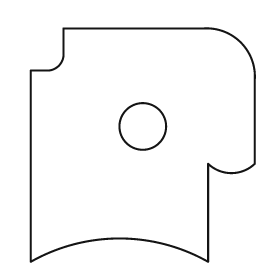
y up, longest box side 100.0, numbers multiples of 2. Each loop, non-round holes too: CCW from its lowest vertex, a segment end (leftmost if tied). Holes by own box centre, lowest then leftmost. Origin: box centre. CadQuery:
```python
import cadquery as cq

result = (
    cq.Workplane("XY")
    .moveTo(-48.0, -50.0)
    .threePointArc((-10.0, -40.0), (28.0, -50.0))
    .lineTo(28.0, -8.0)
    .threePointArc((38.0, -12.0), (48.0, -8.0))
    .lineTo(48.0, 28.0)
    .threePointArc((42.0, 44.0), (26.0, 50.0))
    .lineTo(-34.0, 50.0)
    .lineTo(-34.0, 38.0)
    .threePointArc((-36.0, 34.0), (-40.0, 32.0))
    .lineTo(-48.0, 32.0)
    .close()
    .moveTo(0.0, 8.0)
    .circle(10.0)
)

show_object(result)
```